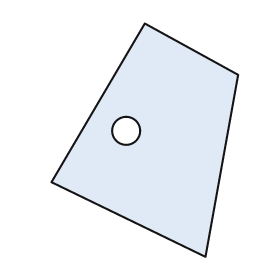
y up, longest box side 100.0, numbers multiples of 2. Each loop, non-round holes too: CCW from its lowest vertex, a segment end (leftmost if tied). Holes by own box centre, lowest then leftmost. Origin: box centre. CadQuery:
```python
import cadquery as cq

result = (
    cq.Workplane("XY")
    .moveTo(26.0, -50.0)
    .lineTo(40.0, 28.0)
    .lineTo(0.0, 50.0)
    .lineTo(-40.0, -18.0)
    .close()
    .moveTo(-8.0, 4.0)
    .circle(6.0)
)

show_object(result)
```